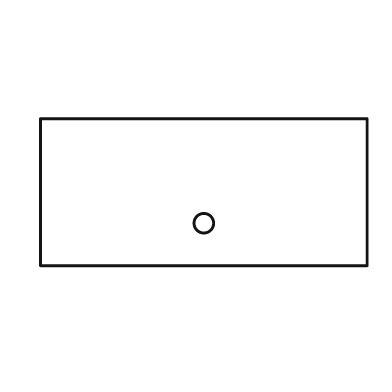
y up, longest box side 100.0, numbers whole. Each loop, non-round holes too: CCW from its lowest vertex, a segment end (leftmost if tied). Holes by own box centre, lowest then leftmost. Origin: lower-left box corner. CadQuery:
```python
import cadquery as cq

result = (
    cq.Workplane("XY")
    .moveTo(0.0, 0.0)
    .lineTo(100.0, 0.0)
    .lineTo(100.0, 45.0)
    .lineTo(0.0, 45.0)
    .close()
    .moveTo(50.0, 13.0)
    .circle(3.0)
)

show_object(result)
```